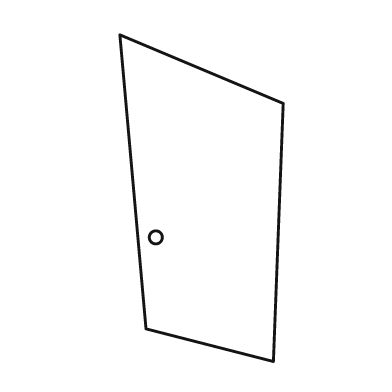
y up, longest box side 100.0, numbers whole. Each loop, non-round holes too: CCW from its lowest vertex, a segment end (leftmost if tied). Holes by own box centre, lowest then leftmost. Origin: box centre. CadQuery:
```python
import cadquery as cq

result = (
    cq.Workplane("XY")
    .moveTo(22.0, -50.0)
    .lineTo(25.0, 29.0)
    .lineTo(-25.0, 50.0)
    .lineTo(-17.0, -40.0)
    .close()
    .moveTo(-14.0, -12.0)
    .circle(2.0)
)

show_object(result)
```